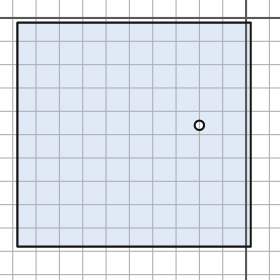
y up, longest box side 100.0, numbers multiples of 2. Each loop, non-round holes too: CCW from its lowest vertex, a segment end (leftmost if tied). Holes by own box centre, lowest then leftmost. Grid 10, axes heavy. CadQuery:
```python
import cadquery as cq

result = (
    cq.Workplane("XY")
    .moveTo(-98.0, -98.0)
    .lineTo(2.0, -98.0)
    .lineTo(2.0, -2.0)
    .lineTo(-98.0, -2.0)
    .close()
    .moveTo(-20.0, -46.0)
    .circle(2.0)
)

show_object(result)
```